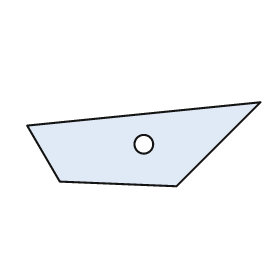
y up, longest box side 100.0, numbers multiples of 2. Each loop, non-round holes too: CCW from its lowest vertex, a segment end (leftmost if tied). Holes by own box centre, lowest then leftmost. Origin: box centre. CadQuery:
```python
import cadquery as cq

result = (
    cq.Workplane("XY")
    .moveTo(14.0, -18.0)
    .lineTo(50.0, 18.0)
    .lineTo(-50.0, 8.0)
    .lineTo(-36.0, -16.0)
    .close()
    .moveTo(0.0, 0.0)
    .circle(4.0)
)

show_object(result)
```